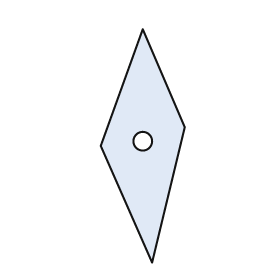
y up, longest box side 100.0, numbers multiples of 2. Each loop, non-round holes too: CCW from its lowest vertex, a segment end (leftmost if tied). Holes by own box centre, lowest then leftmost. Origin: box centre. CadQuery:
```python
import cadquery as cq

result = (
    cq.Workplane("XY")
    .moveTo(4.0, -50.0)
    .lineTo(18.0, 8.0)
    .lineTo(0.0, 50.0)
    .lineTo(-18.0, 0.0)
    .close()
    .moveTo(0.0, 2.0)
    .circle(4.0)
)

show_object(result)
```